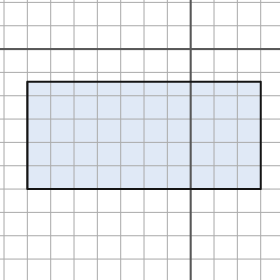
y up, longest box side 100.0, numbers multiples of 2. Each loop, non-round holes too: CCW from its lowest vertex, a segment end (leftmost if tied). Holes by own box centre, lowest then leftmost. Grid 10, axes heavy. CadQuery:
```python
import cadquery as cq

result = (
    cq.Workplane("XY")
    .moveTo(-70.0, -60.0)
    .lineTo(30.0, -60.0)
    .lineTo(30.0, -14.0)
    .lineTo(-70.0, -14.0)
    .close()
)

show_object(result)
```